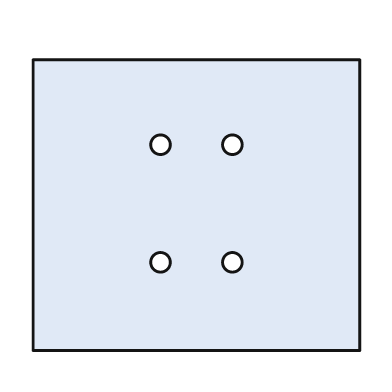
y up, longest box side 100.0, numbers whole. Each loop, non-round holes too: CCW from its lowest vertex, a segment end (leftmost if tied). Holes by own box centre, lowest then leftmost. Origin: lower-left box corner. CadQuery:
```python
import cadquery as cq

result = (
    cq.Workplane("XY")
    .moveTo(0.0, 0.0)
    .lineTo(100.0, 0.0)
    .lineTo(100.0, 89.0)
    .lineTo(0.0, 89.0)
    .close()
    .moveTo(39.0, 27.0)
    .circle(3.0)
    .moveTo(61.0, 27.0)
    .circle(3.0)
    .moveTo(39.0, 63.0)
    .circle(3.0)
    .moveTo(61.0, 63.0)
    .circle(3.0)
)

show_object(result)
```